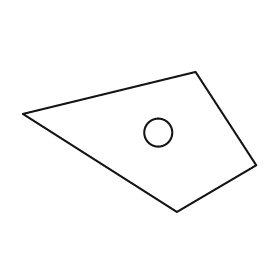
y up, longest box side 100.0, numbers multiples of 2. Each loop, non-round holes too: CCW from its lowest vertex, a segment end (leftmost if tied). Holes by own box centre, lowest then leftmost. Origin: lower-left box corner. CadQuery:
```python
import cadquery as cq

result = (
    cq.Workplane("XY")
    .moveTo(66.0, 0.0)
    .lineTo(100.0, 20.0)
    .lineTo(74.0, 60.0)
    .lineTo(0.0, 42.0)
    .close()
    .moveTo(58.0, 34.0)
    .circle(6.0)
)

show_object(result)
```